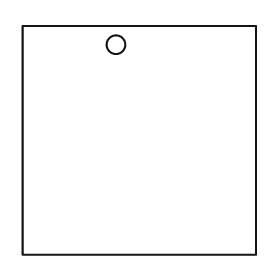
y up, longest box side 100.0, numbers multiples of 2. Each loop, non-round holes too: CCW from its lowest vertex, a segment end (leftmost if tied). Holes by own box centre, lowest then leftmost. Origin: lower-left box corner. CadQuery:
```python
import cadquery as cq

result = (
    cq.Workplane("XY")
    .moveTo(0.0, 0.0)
    .lineTo(100.0, 0.0)
    .lineTo(100.0, 98.0)
    .lineTo(0.0, 98.0)
    .close()
    .moveTo(40.0, 90.0)
    .circle(4.0)
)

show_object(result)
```